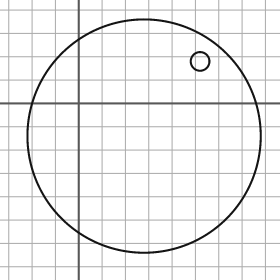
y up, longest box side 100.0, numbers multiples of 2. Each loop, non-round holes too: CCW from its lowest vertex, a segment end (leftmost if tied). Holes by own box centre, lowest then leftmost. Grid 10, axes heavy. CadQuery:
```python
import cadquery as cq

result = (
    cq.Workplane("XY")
    .moveTo(28.0, -14.0)
    .circle(50.0)
    .moveTo(52.0, 18.0)
    .circle(4.0)
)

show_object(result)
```